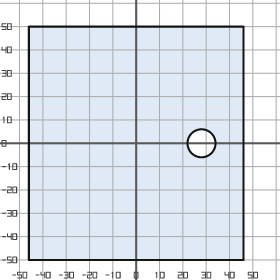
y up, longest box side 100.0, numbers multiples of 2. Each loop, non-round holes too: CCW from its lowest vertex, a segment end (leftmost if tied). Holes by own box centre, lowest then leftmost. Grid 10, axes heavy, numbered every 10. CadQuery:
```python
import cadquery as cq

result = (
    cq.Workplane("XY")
    .moveTo(-46.0, -50.0)
    .lineTo(46.0, -50.0)
    .lineTo(46.0, 50.0)
    .lineTo(-46.0, 50.0)
    .close()
    .moveTo(28.0, 0.0)
    .circle(6.0)
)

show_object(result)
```